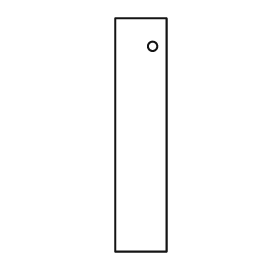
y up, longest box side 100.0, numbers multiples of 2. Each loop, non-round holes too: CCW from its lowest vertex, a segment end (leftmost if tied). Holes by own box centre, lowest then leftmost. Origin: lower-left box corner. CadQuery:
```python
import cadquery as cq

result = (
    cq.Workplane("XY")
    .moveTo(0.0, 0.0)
    .lineTo(22.0, 0.0)
    .lineTo(22.0, 100.0)
    .lineTo(0.0, 100.0)
    .close()
    .moveTo(16.0, 88.0)
    .circle(2.0)
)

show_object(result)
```